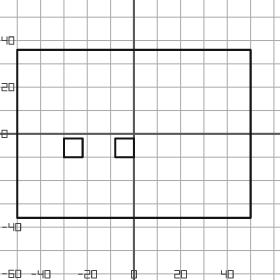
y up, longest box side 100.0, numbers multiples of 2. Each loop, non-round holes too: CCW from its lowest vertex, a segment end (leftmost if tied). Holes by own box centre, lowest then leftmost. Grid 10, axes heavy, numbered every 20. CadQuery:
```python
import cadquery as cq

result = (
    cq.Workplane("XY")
    .moveTo(-50.0, -36.0)
    .lineTo(50.0, -36.0)
    .lineTo(50.0, 36.0)
    .lineTo(-50.0, 36.0)
    .close()
    .moveTo(-30.0, -10.0)
    .lineTo(-22.0, -10.0)
    .lineTo(-22.0, -2.0)
    .lineTo(-30.0, -2.0)
    .close()
    .moveTo(-8.0, -10.0)
    .lineTo(0.0, -10.0)
    .lineTo(0.0, -2.0)
    .lineTo(-8.0, -2.0)
    .close()
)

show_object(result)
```